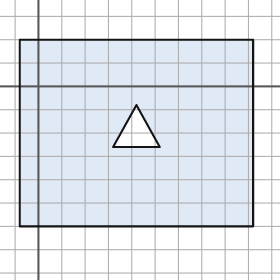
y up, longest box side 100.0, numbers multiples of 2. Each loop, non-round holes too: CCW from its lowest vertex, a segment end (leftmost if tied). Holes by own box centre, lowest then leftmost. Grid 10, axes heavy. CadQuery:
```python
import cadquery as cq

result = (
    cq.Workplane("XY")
    .moveTo(-8.0, -60.0)
    .lineTo(92.0, -60.0)
    .lineTo(92.0, 20.0)
    .lineTo(-8.0, 20.0)
    .close()
    .moveTo(32.0, -26.0)
    .lineTo(52.0, -26.0)
    .lineTo(42.0, -8.0)
    .close()
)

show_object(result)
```